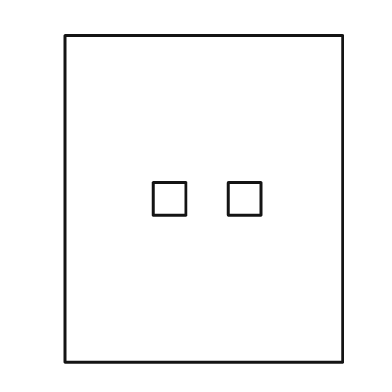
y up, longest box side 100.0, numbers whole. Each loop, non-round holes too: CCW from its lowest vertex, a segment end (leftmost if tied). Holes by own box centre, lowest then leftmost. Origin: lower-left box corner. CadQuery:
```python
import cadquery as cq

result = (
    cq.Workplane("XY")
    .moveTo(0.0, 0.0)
    .lineTo(85.0, 0.0)
    .lineTo(85.0, 100.0)
    .lineTo(0.0, 100.0)
    .close()
    .moveTo(27.0, 45.0)
    .lineTo(37.0, 45.0)
    .lineTo(37.0, 55.0)
    .lineTo(27.0, 55.0)
    .close()
    .moveTo(50.0, 45.0)
    .lineTo(60.0, 45.0)
    .lineTo(60.0, 55.0)
    .lineTo(50.0, 55.0)
    .close()
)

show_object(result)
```